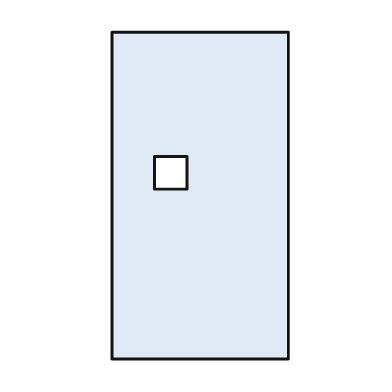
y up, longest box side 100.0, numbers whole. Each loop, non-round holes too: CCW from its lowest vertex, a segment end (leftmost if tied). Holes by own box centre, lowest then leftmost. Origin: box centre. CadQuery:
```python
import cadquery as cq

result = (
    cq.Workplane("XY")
    .moveTo(-27.0, -50.0)
    .lineTo(27.0, -50.0)
    .lineTo(27.0, 50.0)
    .lineTo(-27.0, 50.0)
    .close()
    .moveTo(-14.0, 2.0)
    .lineTo(-4.0, 2.0)
    .lineTo(-4.0, 12.0)
    .lineTo(-14.0, 12.0)
    .close()
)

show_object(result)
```